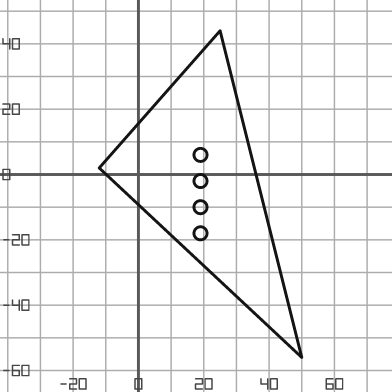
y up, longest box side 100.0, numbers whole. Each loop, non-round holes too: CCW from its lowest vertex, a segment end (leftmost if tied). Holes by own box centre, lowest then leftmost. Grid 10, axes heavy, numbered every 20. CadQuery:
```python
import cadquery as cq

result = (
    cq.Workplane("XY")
    .moveTo(50.0, -56.0)
    .lineTo(25.0, 44.0)
    .lineTo(-12.0, 2.0)
    .close()
    .moveTo(19.0, -18.0)
    .circle(2.0)
    .moveTo(19.0, -10.0)
    .circle(2.0)
    .moveTo(19.0, -2.0)
    .circle(2.0)
    .moveTo(19.0, 6.0)
    .circle(2.0)
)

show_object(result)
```